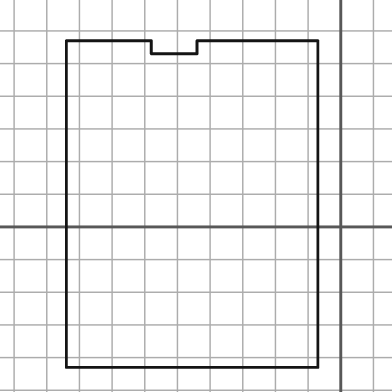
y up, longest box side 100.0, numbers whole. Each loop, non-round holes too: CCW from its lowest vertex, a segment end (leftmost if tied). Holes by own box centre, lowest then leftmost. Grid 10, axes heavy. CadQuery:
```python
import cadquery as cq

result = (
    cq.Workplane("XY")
    .moveTo(-84.0, -43.0)
    .lineTo(-7.0, -43.0)
    .lineTo(-7.0, 57.0)
    .lineTo(-44.0, 57.0)
    .lineTo(-44.0, 53.0)
    .lineTo(-58.0, 53.0)
    .lineTo(-58.0, 57.0)
    .lineTo(-84.0, 57.0)
    .close()
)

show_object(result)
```